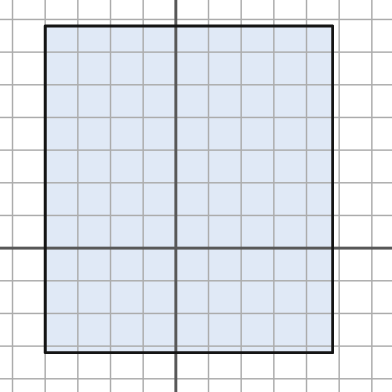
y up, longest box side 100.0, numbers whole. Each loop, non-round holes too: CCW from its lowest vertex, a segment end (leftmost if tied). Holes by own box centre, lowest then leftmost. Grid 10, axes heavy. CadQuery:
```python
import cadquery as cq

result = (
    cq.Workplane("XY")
    .moveTo(-40.0, -32.0)
    .lineTo(48.0, -32.0)
    .lineTo(48.0, 68.0)
    .lineTo(-40.0, 68.0)
    .close()
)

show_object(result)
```